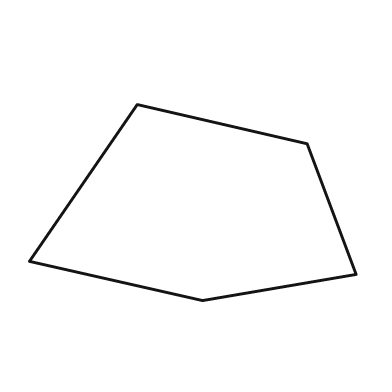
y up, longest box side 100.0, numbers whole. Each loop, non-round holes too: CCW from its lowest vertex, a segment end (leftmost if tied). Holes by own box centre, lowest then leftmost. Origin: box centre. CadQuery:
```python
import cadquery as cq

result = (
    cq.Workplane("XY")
    .moveTo(3.0, -30.0)
    .lineTo(50.0, -22.0)
    .lineTo(35.0, 18.0)
    .lineTo(-17.0, 30.0)
    .lineTo(-50.0, -18.0)
    .close()
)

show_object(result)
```